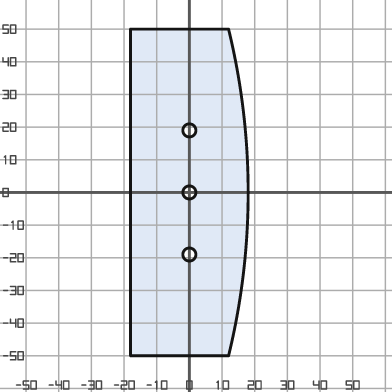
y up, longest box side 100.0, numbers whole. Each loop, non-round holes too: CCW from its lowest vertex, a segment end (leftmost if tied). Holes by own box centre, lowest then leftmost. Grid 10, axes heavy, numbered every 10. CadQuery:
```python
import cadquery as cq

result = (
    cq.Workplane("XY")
    .moveTo(-18.0, -50.0)
    .lineTo(12.0, -50.0)
    .threePointArc((18.0, 0.0), (12.0, 50.0))
    .lineTo(-18.0, 50.0)
    .close()
    .moveTo(0.0, -19.0)
    .circle(2.0)
    .moveTo(0.0, 0.0)
    .circle(2.0)
    .moveTo(0.0, 19.0)
    .circle(2.0)
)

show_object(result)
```